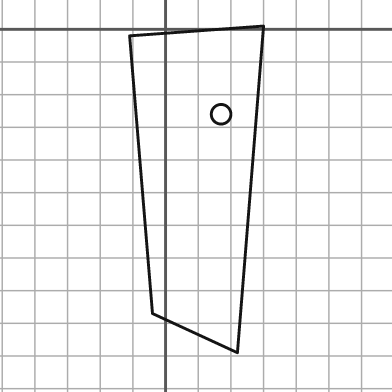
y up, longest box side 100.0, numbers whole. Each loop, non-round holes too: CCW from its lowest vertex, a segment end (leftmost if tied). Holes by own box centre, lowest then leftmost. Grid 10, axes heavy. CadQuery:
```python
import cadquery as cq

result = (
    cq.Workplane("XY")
    .moveTo(22.0, -99.0)
    .lineTo(30.0, 1.0)
    .lineTo(-11.0, -2.0)
    .lineTo(-4.0, -87.0)
    .close()
    .moveTo(17.0, -26.0)
    .circle(3.0)
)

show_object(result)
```